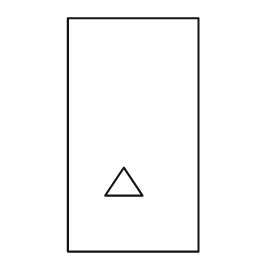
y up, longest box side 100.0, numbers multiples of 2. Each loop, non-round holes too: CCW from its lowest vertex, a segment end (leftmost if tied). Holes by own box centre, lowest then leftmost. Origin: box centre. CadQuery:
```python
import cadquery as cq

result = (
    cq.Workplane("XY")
    .moveTo(-28.0, -50.0)
    .lineTo(28.0, -50.0)
    .lineTo(28.0, 50.0)
    .lineTo(-28.0, 50.0)
    .close()
    .moveTo(-12.0, -26.0)
    .lineTo(4.0, -26.0)
    .lineTo(-4.0, -14.0)
    .close()
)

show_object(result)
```